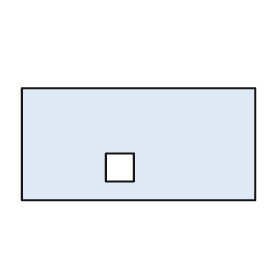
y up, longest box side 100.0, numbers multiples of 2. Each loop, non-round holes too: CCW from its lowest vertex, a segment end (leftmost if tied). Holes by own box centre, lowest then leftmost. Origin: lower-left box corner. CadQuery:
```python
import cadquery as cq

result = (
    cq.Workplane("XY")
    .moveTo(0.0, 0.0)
    .lineTo(100.0, 0.0)
    .lineTo(100.0, 48.0)
    .lineTo(0.0, 48.0)
    .close()
    .moveTo(36.0, 8.0)
    .lineTo(48.0, 8.0)
    .lineTo(48.0, 20.0)
    .lineTo(36.0, 20.0)
    .close()
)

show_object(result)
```